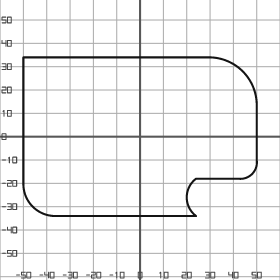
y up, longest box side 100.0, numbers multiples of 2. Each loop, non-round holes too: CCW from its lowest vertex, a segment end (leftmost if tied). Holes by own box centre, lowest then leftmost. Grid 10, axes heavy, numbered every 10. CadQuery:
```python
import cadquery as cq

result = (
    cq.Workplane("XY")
    .moveTo(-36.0, -34.0)
    .lineTo(24.0, -34.0)
    .threePointArc((20.0, -26.0), (24.0, -18.0))
    .lineTo(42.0, -18.0)
    .threePointArc((48.0, -16.0), (50.0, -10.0))
    .lineTo(50.0, 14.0)
    .threePointArc((44.0, 28.0), (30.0, 34.0))
    .lineTo(-50.0, 34.0)
    .lineTo(-50.0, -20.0)
    .threePointArc((-46.0, -30.0), (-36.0, -34.0))
    .close()
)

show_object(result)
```